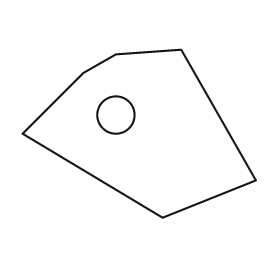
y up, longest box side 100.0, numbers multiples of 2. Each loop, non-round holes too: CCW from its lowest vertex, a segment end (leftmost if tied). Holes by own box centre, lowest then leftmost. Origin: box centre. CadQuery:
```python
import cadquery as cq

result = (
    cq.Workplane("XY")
    .moveTo(10.0, -36.0)
    .lineTo(50.0, -20.0)
    .lineTo(18.0, 36.0)
    .lineTo(-10.0, 34.0)
    .lineTo(-24.0, 26.0)
    .lineTo(-50.0, 0.0)
    .close()
    .moveTo(-10.0, 8.0)
    .circle(8.0)
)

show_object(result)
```